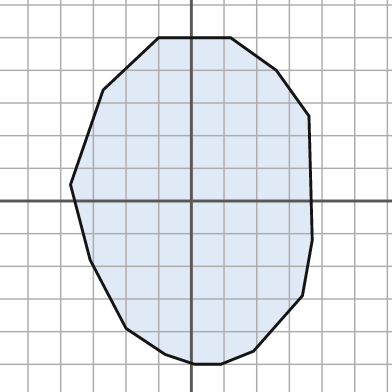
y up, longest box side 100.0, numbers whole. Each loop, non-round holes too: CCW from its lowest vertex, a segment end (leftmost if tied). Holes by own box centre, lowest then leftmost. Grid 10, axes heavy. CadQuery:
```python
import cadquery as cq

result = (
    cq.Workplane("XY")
    .moveTo(1.0, -50.0)
    .lineTo(9.0, -50.0)
    .lineTo(19.0, -46.0)
    .lineTo(34.0, -29.0)
    .lineTo(37.0, -12.0)
    .lineTo(36.0, 26.0)
    .lineTo(26.0, 40.0)
    .lineTo(12.0, 50.0)
    .lineTo(-10.0, 50.0)
    .lineTo(-27.0, 34.0)
    .lineTo(-37.0, 5.0)
    .lineTo(-31.0, -18.0)
    .lineTo(-20.0, -39.0)
    .lineTo(-8.0, -47.0)
    .close()
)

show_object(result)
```